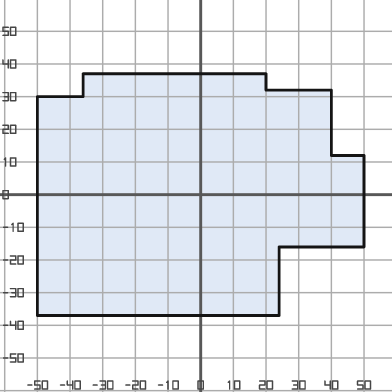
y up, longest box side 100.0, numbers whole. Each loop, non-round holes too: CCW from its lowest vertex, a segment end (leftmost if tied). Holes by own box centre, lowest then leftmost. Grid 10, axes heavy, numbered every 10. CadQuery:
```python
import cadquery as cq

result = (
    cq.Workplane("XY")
    .moveTo(-50.0, -37.0)
    .lineTo(24.0, -37.0)
    .lineTo(24.0, -16.0)
    .lineTo(50.0, -16.0)
    .lineTo(50.0, 12.0)
    .lineTo(40.0, 12.0)
    .lineTo(40.0, 32.0)
    .lineTo(20.0, 32.0)
    .lineTo(20.0, 37.0)
    .lineTo(-36.0, 37.0)
    .lineTo(-36.0, 30.0)
    .lineTo(-50.0, 30.0)
    .close()
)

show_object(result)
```